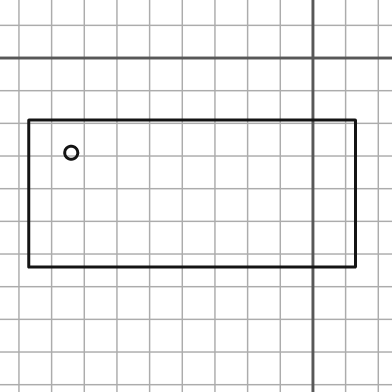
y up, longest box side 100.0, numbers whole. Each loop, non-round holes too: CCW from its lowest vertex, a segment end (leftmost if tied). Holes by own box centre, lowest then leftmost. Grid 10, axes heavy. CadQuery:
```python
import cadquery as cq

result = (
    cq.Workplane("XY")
    .moveTo(-87.0, -64.0)
    .lineTo(13.0, -64.0)
    .lineTo(13.0, -19.0)
    .lineTo(-87.0, -19.0)
    .close()
    .moveTo(-74.0, -29.0)
    .circle(2.0)
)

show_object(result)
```